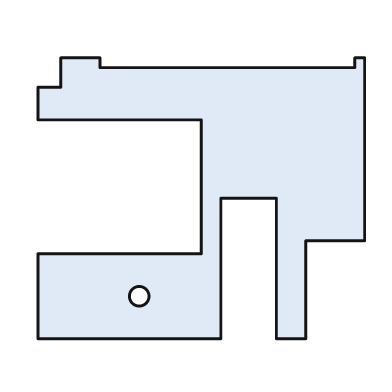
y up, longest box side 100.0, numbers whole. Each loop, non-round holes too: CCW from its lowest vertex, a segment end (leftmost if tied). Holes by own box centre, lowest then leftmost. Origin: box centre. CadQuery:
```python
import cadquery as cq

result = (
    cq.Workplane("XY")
    .moveTo(-50.0, -43.0)
    .lineTo(6.0, -43.0)
    .lineTo(6.0, 0.0)
    .lineTo(23.0, 0.0)
    .lineTo(23.0, -43.0)
    .lineTo(32.0, -43.0)
    .lineTo(32.0, -13.0)
    .lineTo(50.0, -13.0)
    .lineTo(50.0, 43.0)
    .lineTo(47.0, 43.0)
    .lineTo(47.0, 40.0)
    .lineTo(-31.0, 40.0)
    .lineTo(-31.0, 43.0)
    .lineTo(-43.0, 43.0)
    .lineTo(-43.0, 34.0)
    .lineTo(-50.0, 34.0)
    .lineTo(-50.0, 24.0)
    .lineTo(0.0, 24.0)
    .lineTo(0.0, -17.0)
    .lineTo(-50.0, -17.0)
    .close()
    .moveTo(-19.0, -30.0)
    .circle(3.0)
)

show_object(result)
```